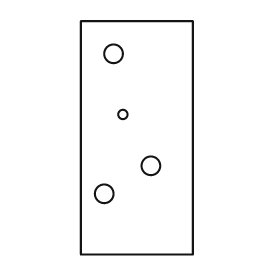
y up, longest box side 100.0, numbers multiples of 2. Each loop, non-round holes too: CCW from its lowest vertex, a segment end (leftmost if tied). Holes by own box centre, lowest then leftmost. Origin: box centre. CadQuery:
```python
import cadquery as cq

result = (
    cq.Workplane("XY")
    .moveTo(-24.0, -50.0)
    .lineTo(24.0, -50.0)
    .lineTo(24.0, 50.0)
    .lineTo(-24.0, 50.0)
    .close()
    .moveTo(-14.0, -24.0)
    .circle(4.0)
    .moveTo(6.0, -12.0)
    .circle(4.0)
    .moveTo(-6.0, 10.0)
    .circle(2.0)
    .moveTo(-10.0, 36.0)
    .circle(4.0)
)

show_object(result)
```